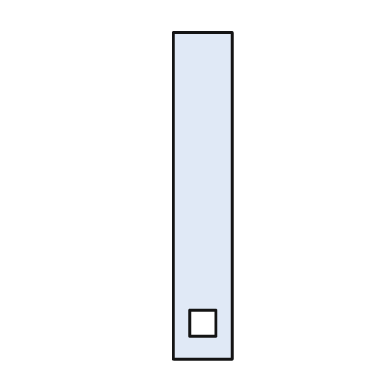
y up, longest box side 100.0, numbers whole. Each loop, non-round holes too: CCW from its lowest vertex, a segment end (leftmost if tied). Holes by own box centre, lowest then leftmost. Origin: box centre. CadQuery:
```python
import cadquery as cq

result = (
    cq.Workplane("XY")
    .moveTo(-9.0, -50.0)
    .lineTo(9.0, -50.0)
    .lineTo(9.0, 50.0)
    .lineTo(-9.0, 50.0)
    .close()
    .moveTo(-4.0, -43.0)
    .lineTo(4.0, -43.0)
    .lineTo(4.0, -35.0)
    .lineTo(-4.0, -35.0)
    .close()
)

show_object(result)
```